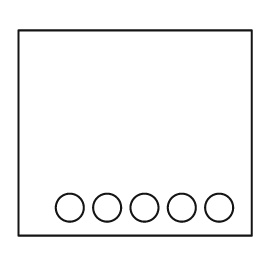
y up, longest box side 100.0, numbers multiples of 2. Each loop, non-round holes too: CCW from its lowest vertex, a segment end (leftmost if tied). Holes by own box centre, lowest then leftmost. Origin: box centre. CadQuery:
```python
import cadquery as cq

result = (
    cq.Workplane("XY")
    .moveTo(-50.0, -44.0)
    .lineTo(50.0, -44.0)
    .lineTo(50.0, 44.0)
    .lineTo(-50.0, 44.0)
    .close()
    .moveTo(-28.0, -32.0)
    .circle(6.0)
    .moveTo(-12.0, -32.0)
    .circle(6.0)
    .moveTo(4.0, -32.0)
    .circle(6.0)
    .moveTo(20.0, -32.0)
    .circle(6.0)
    .moveTo(36.0, -32.0)
    .circle(6.0)
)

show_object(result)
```